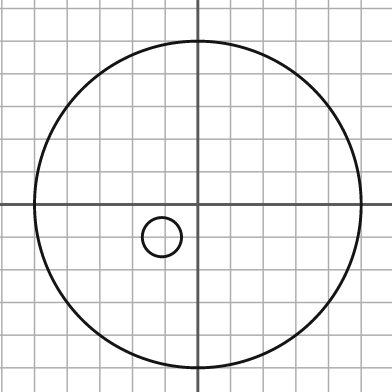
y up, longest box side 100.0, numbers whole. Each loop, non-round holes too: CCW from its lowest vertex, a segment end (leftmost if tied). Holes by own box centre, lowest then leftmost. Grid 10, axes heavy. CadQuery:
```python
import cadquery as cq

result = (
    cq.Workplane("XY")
    .moveTo(0.0, 0.0)
    .circle(50.0)
    .moveTo(-11.0, -10.0)
    .circle(6.0)
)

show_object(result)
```